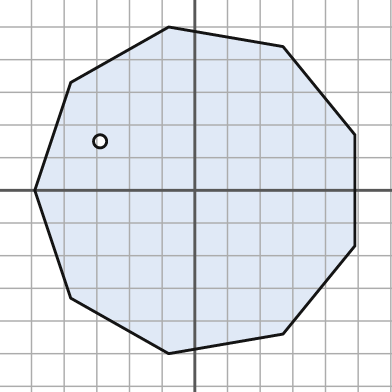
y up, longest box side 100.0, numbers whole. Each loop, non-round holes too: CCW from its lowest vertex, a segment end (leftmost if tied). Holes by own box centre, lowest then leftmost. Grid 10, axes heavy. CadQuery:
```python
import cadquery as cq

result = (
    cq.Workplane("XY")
    .moveTo(-8.0, -50.0)
    .lineTo(27.0, -44.0)
    .lineTo(49.0, -17.0)
    .lineTo(49.0, 17.0)
    .lineTo(27.0, 44.0)
    .lineTo(-8.0, 50.0)
    .lineTo(-38.0, 33.0)
    .lineTo(-49.0, 0.0)
    .lineTo(-38.0, -33.0)
    .close()
    .moveTo(-29.0, 15.0)
    .circle(2.0)
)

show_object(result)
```